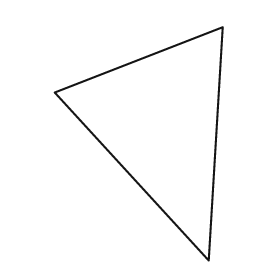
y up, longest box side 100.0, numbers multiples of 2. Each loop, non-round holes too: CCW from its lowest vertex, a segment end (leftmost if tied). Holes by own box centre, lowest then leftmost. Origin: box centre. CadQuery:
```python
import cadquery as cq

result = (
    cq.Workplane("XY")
    .moveTo(30.0, -50.0)
    .lineTo(36.0, 50.0)
    .lineTo(-36.0, 22.0)
    .close()
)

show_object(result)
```